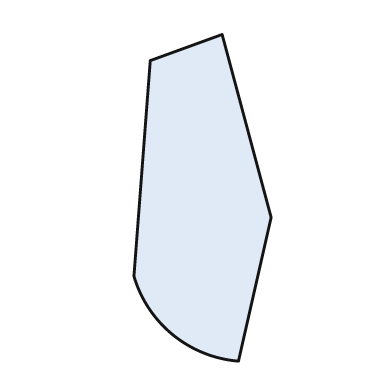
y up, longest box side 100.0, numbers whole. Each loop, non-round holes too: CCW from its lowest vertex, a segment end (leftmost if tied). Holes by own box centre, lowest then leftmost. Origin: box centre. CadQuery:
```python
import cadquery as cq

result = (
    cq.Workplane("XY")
    .moveTo(11.0, -50.0)
    .lineTo(21.0, -6.0)
    .lineTo(6.0, 50.0)
    .lineTo(-16.0, 42.0)
    .lineTo(-21.0, -24.0)
    .threePointArc((-9.0, -42.0), (11.0, -50.0))
    .close()
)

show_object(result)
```